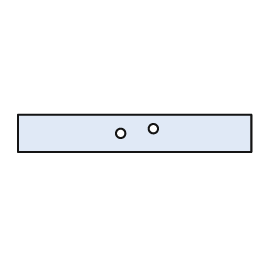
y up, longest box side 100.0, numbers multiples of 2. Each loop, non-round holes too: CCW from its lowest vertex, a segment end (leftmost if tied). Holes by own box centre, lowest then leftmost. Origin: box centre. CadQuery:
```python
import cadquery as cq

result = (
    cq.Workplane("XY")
    .moveTo(-50.0, -8.0)
    .lineTo(50.0, -8.0)
    .lineTo(50.0, 8.0)
    .lineTo(-50.0, 8.0)
    .close()
    .moveTo(-6.0, 0.0)
    .circle(2.0)
    .moveTo(8.0, 2.0)
    .circle(2.0)
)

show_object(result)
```